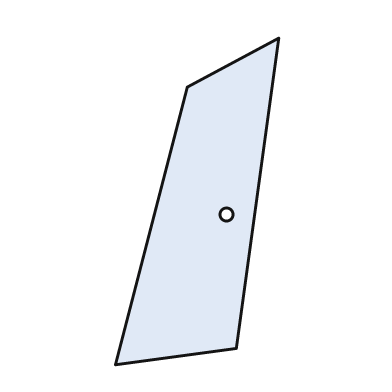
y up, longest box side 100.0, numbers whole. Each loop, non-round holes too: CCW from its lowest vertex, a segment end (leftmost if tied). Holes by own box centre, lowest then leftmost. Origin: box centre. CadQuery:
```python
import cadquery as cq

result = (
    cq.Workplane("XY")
    .moveTo(-25.0, -50.0)
    .lineTo(12.0, -45.0)
    .lineTo(25.0, 50.0)
    .lineTo(-3.0, 35.0)
    .close()
    .moveTo(9.0, -4.0)
    .circle(2.0)
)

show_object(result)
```